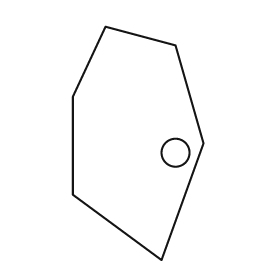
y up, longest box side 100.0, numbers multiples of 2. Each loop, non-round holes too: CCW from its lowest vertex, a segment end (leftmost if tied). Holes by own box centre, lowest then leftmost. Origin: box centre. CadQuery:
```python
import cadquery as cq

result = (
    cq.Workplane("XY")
    .moveTo(10.0, -50.0)
    .lineTo(28.0, 0.0)
    .lineTo(16.0, 42.0)
    .lineTo(-14.0, 50.0)
    .lineTo(-28.0, 20.0)
    .lineTo(-28.0, -22.0)
    .close()
    .moveTo(16.0, -4.0)
    .circle(6.0)
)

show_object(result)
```